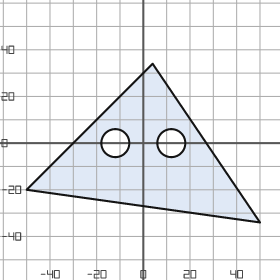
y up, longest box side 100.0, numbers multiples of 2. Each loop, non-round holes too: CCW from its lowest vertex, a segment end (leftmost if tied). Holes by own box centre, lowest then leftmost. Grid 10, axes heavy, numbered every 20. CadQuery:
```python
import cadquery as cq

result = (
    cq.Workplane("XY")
    .moveTo(50.0, -34.0)
    .lineTo(4.0, 34.0)
    .lineTo(-50.0, -20.0)
    .close()
    .moveTo(-12.0, 0.0)
    .circle(6.0)
    .moveTo(12.0, 0.0)
    .circle(6.0)
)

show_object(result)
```